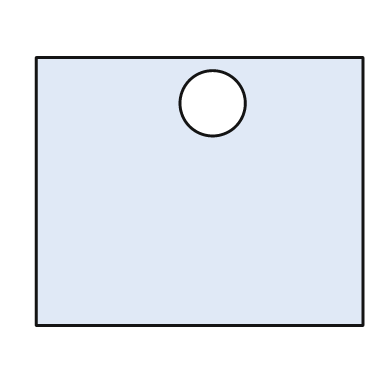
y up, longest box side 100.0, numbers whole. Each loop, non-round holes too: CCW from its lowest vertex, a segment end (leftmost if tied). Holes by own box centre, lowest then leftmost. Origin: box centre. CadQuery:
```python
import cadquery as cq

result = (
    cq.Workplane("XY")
    .moveTo(-50.0, -41.0)
    .lineTo(50.0, -41.0)
    .lineTo(50.0, 41.0)
    .lineTo(-50.0, 41.0)
    .close()
    .moveTo(4.0, 27.0)
    .circle(10.0)
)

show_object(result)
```